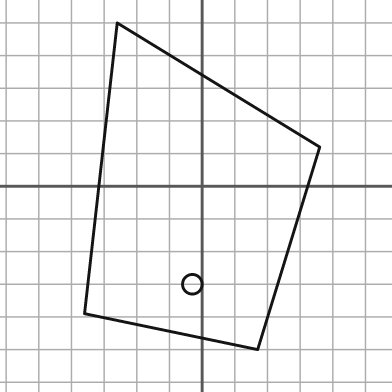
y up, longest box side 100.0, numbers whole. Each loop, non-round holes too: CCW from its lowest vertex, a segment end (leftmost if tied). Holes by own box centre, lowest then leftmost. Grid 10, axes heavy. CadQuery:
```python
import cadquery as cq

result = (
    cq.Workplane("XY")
    .moveTo(17.0, -50.0)
    .lineTo(36.0, 12.0)
    .lineTo(-26.0, 50.0)
    .lineTo(-36.0, -39.0)
    .close()
    .moveTo(-3.0, -30.0)
    .circle(3.0)
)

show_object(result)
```